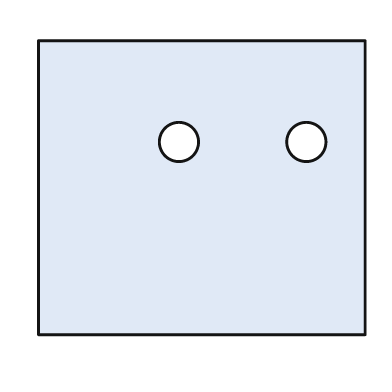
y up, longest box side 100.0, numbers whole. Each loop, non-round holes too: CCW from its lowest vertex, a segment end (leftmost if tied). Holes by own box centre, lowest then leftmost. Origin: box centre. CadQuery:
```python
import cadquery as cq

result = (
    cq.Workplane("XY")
    .moveTo(-50.0, -45.0)
    .lineTo(50.0, -45.0)
    .lineTo(50.0, 45.0)
    .lineTo(-50.0, 45.0)
    .close()
    .moveTo(-7.0, 14.0)
    .circle(6.0)
    .moveTo(32.0, 14.0)
    .circle(6.0)
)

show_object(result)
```